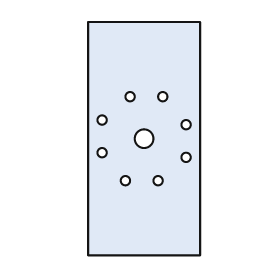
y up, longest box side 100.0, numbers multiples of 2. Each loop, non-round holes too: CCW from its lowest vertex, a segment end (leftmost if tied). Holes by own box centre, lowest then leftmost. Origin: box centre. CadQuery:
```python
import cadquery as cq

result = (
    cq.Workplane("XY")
    .moveTo(-24.0, -50.0)
    .lineTo(24.0, -50.0)
    .lineTo(24.0, 50.0)
    .lineTo(-24.0, 50.0)
    .close()
    .moveTo(-8.0, -18.0)
    .circle(2.0)
    .moveTo(6.0, -18.0)
    .circle(2.0)
    .moveTo(18.0, -8.0)
    .circle(2.0)
    .moveTo(-18.0, -6.0)
    .circle(2.0)
    .moveTo(0.0, 0.0)
    .circle(4.0)
    .moveTo(18.0, 6.0)
    .circle(2.0)
    .moveTo(-18.0, 8.0)
    .circle(2.0)
    .moveTo(-6.0, 18.0)
    .circle(2.0)
    .moveTo(8.0, 18.0)
    .circle(2.0)
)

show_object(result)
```